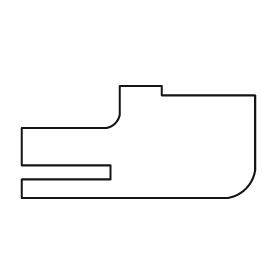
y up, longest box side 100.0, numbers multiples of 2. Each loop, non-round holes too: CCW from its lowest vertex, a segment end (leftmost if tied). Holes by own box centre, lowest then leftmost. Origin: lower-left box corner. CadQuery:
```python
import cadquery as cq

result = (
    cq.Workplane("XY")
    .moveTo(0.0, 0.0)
    .lineTo(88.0, 0.0)
    .threePointArc((96.0, 4.0), (100.0, 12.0))
    .lineTo(100.0, 44.0)
    .lineTo(60.0, 44.0)
    .lineTo(60.0, 48.0)
    .lineTo(42.0, 48.0)
    .lineTo(42.0, 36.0)
    .threePointArc((40.0, 32.0), (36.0, 30.0))
    .lineTo(0.0, 30.0)
    .lineTo(0.0, 14.0)
    .lineTo(38.0, 14.0)
    .lineTo(38.0, 8.0)
    .lineTo(0.0, 8.0)
    .close()
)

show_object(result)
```